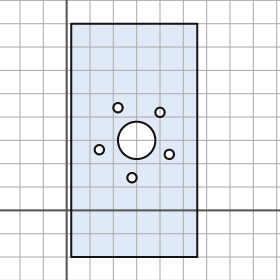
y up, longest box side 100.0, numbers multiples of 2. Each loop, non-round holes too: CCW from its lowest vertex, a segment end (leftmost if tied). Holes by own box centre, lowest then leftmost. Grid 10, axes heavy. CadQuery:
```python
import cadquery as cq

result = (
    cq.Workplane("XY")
    .moveTo(2.0, -20.0)
    .lineTo(56.0, -20.0)
    .lineTo(56.0, 80.0)
    .lineTo(2.0, 80.0)
    .close()
    .moveTo(28.0, 14.0)
    .circle(2.0)
    .moveTo(44.0, 24.0)
    .circle(2.0)
    .moveTo(14.0, 26.0)
    .circle(2.0)
    .moveTo(30.0, 30.0)
    .circle(8.0)
    .moveTo(40.0, 42.0)
    .circle(2.0)
    .moveTo(22.0, 44.0)
    .circle(2.0)
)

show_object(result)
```